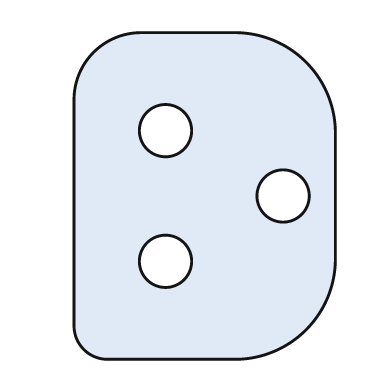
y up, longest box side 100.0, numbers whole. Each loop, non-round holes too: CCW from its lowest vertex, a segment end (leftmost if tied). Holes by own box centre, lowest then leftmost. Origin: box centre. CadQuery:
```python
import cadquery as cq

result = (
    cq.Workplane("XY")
    .moveTo(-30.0, -50.0)
    .lineTo(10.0, -50.0)
    .threePointArc((31.0, -41.0), (40.0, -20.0))
    .lineTo(40.0, 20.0)
    .threePointArc((31.0, 41.0), (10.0, 50.0))
    .lineTo(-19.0, 50.0)
    .threePointArc((-34.0, 44.0), (-40.0, 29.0))
    .lineTo(-40.0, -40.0)
    .threePointArc((-37.0, -47.0), (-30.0, -50.0))
    .close()
    .moveTo(-12.0, -20.0)
    .circle(8.0)
    .moveTo(24.0, 0.0)
    .circle(8.0)
    .moveTo(-12.0, 20.0)
    .circle(8.0)
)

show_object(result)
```